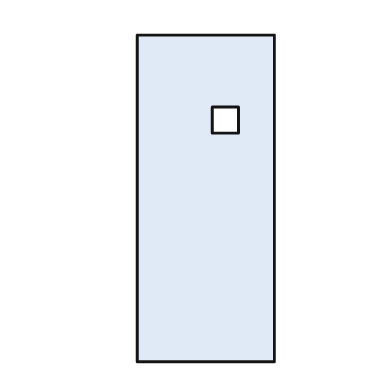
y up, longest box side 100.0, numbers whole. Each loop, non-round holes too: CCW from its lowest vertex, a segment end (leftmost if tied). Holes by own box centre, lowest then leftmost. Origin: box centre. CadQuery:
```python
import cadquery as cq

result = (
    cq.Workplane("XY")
    .moveTo(-21.0, -50.0)
    .lineTo(21.0, -50.0)
    .lineTo(21.0, 50.0)
    .lineTo(-21.0, 50.0)
    .close()
    .moveTo(2.0, 20.0)
    .lineTo(10.0, 20.0)
    .lineTo(10.0, 28.0)
    .lineTo(2.0, 28.0)
    .close()
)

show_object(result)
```